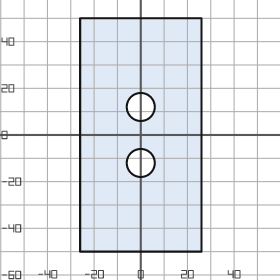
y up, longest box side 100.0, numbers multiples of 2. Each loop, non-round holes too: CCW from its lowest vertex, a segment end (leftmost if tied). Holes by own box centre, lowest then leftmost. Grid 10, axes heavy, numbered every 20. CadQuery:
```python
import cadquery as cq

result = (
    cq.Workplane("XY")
    .moveTo(-26.0, -50.0)
    .lineTo(26.0, -50.0)
    .lineTo(26.0, 50.0)
    .lineTo(-26.0, 50.0)
    .close()
    .moveTo(0.0, -12.0)
    .circle(6.0)
    .moveTo(0.0, 12.0)
    .circle(6.0)
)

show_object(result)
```